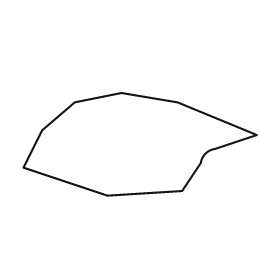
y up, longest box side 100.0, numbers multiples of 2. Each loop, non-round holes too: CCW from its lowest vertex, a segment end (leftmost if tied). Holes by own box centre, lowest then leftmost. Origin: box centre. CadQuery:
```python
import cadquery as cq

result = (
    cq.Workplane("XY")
    .moveTo(-14.0, -22.0)
    .lineTo(18.0, -20.0)
    .lineTo(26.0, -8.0)
    .threePointArc((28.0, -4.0), (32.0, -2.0))
    .lineTo(50.0, 4.0)
    .lineTo(16.0, 18.0)
    .lineTo(-8.0, 22.0)
    .lineTo(-28.0, 18.0)
    .lineTo(-42.0, 6.0)
    .lineTo(-50.0, -10.0)
    .close()
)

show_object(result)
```